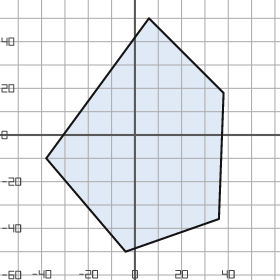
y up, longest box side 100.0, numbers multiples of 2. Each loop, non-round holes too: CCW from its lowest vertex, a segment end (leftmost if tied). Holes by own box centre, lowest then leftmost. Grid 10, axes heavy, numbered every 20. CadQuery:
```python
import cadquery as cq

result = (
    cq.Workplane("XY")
    .moveTo(-4.0, -50.0)
    .lineTo(36.0, -36.0)
    .lineTo(38.0, 18.0)
    .lineTo(6.0, 50.0)
    .lineTo(-38.0, -10.0)
    .close()
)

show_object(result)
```